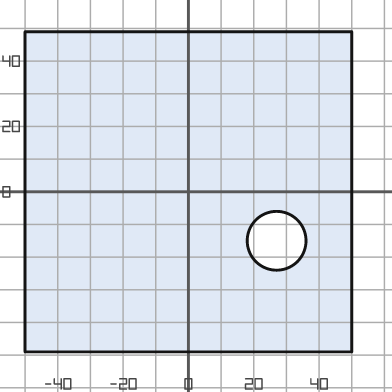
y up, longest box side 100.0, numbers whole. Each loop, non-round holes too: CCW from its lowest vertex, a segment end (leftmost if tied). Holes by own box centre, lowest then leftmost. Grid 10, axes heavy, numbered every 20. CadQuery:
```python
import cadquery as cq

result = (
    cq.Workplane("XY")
    .moveTo(-50.0, -49.0)
    .lineTo(50.0, -49.0)
    .lineTo(50.0, 49.0)
    .lineTo(-50.0, 49.0)
    .close()
    .moveTo(27.0, -15.0)
    .circle(9.0)
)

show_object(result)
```